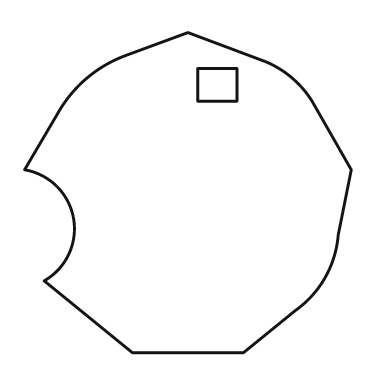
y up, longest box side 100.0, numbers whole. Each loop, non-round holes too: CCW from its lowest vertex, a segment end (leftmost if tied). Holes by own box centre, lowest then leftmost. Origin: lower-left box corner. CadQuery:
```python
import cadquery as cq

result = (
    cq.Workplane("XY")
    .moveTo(33.0, 0.0)
    .lineTo(67.0, 0.0)
    .lineTo(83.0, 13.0)
    .threePointArc((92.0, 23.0), (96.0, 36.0))
    .lineTo(100.0, 56.0)
    .lineTo(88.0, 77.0)
    .threePointArc((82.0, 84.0), (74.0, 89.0))
    .lineTo(50.0, 98.0)
    .lineTo(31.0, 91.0)
    .threePointArc((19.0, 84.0), (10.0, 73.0))
    .lineTo(0.0, 56.0)
    .threePointArc((15.0, 41.0), (6.0, 22.0))
    .close()
    .moveTo(53.0, 77.0)
    .lineTo(65.0, 77.0)
    .lineTo(65.0, 87.0)
    .lineTo(53.0, 87.0)
    .close()
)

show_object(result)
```